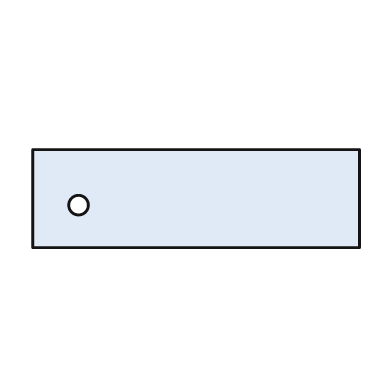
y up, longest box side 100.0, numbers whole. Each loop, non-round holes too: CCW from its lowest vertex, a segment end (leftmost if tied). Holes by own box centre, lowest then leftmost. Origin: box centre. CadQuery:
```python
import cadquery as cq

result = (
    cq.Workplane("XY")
    .moveTo(-50.0, -15.0)
    .lineTo(50.0, -15.0)
    .lineTo(50.0, 15.0)
    .lineTo(-50.0, 15.0)
    .close()
    .moveTo(-36.0, -2.0)
    .circle(3.0)
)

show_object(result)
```